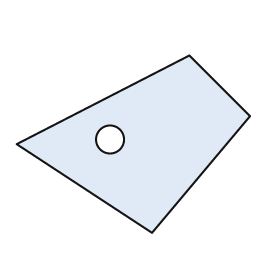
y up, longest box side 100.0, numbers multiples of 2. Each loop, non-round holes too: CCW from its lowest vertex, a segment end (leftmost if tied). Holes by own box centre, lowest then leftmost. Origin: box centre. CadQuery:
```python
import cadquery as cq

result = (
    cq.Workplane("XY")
    .moveTo(8.0, -38.0)
    .lineTo(50.0, 12.0)
    .lineTo(24.0, 38.0)
    .lineTo(-50.0, 0.0)
    .close()
    .moveTo(-10.0, 2.0)
    .circle(6.0)
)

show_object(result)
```